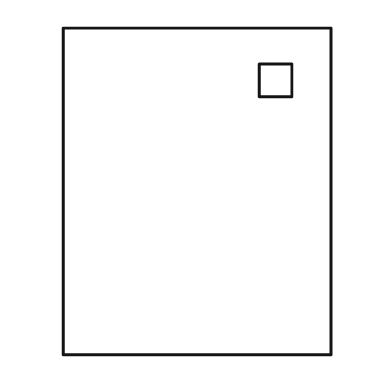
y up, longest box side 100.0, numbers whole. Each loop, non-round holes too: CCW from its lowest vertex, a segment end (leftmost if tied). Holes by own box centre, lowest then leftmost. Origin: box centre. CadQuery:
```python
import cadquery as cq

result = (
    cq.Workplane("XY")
    .moveTo(-41.0, -50.0)
    .lineTo(41.0, -50.0)
    .lineTo(41.0, 50.0)
    .lineTo(-41.0, 50.0)
    .close()
    .moveTo(19.0, 29.0)
    .lineTo(29.0, 29.0)
    .lineTo(29.0, 39.0)
    .lineTo(19.0, 39.0)
    .close()
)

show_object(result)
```